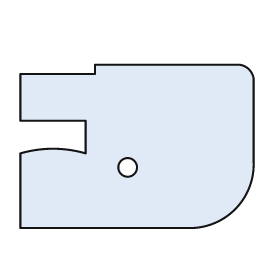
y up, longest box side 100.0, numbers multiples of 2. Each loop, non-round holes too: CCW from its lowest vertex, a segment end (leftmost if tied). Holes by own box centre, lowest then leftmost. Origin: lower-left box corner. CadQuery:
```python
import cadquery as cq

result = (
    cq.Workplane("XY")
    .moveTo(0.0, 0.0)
    .lineTo(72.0, 0.0)
    .threePointArc((92.0, 8.0), (100.0, 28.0))
    .lineTo(100.0, 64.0)
    .threePointArc((98.0, 68.0), (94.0, 70.0))
    .lineTo(32.0, 70.0)
    .lineTo(32.0, 66.0)
    .lineTo(0.0, 66.0)
    .lineTo(0.0, 46.0)
    .lineTo(28.0, 46.0)
    .lineTo(28.0, 32.0)
    .threePointArc((14.0, 34.0), (0.0, 32.0))
    .close()
    .moveTo(46.0, 26.0)
    .circle(4.0)
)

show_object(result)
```